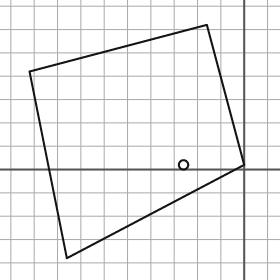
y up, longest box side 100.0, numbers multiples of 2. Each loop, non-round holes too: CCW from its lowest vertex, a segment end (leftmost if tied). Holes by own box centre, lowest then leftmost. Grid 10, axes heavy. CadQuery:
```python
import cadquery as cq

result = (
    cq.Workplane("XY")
    .moveTo(-76.0, -38.0)
    .lineTo(0.0, 2.0)
    .lineTo(-16.0, 62.0)
    .lineTo(-92.0, 42.0)
    .close()
    .moveTo(-26.0, 2.0)
    .circle(2.0)
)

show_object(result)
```